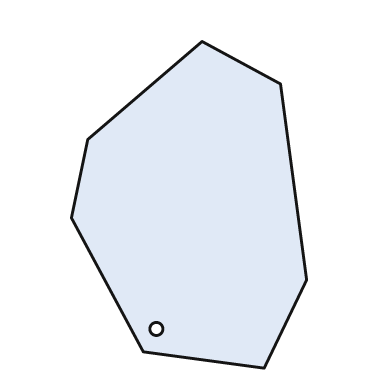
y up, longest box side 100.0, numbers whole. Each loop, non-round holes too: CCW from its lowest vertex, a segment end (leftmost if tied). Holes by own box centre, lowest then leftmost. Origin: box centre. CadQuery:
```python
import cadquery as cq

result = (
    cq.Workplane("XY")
    .moveTo(23.0, -50.0)
    .lineTo(36.0, -23.0)
    .lineTo(28.0, 37.0)
    .lineTo(4.0, 50.0)
    .lineTo(-31.0, 20.0)
    .lineTo(-36.0, -4.0)
    .lineTo(-14.0, -45.0)
    .close()
    .moveTo(-10.0, -38.0)
    .circle(2.0)
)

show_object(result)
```